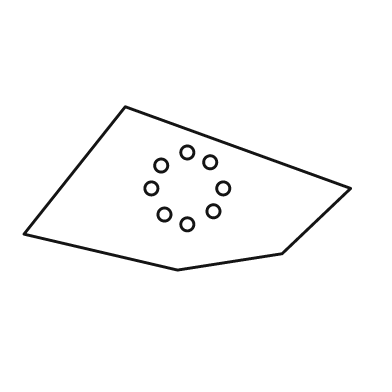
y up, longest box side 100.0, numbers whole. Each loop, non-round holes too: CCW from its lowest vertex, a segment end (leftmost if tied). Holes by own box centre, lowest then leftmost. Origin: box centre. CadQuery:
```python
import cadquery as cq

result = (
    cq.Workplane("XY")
    .moveTo(-3.0, -25.0)
    .lineTo(29.0, -20.0)
    .lineTo(50.0, 0.0)
    .lineTo(-19.0, 25.0)
    .lineTo(-50.0, -14.0)
    .close()
    .moveTo(0.0, -11.0)
    .circle(2.0)
    .moveTo(-7.0, -8.0)
    .circle(2.0)
    .moveTo(8.0, -7.0)
    .circle(2.0)
    .moveTo(-11.0, 0.0)
    .circle(2.0)
    .moveTo(11.0, 0.0)
    .circle(2.0)
    .moveTo(-8.0, 7.0)
    .circle(2.0)
    .moveTo(7.0, 8.0)
    .circle(2.0)
    .moveTo(0.0, 11.0)
    .circle(2.0)
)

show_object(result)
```